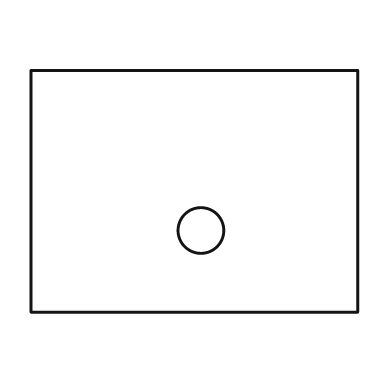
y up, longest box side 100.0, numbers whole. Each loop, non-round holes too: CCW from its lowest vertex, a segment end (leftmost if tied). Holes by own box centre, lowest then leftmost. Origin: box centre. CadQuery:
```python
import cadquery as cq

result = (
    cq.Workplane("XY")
    .moveTo(-50.0, -37.0)
    .lineTo(50.0, -37.0)
    .lineTo(50.0, 37.0)
    .lineTo(-50.0, 37.0)
    .close()
    .moveTo(2.0, -12.0)
    .circle(7.0)
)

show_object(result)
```